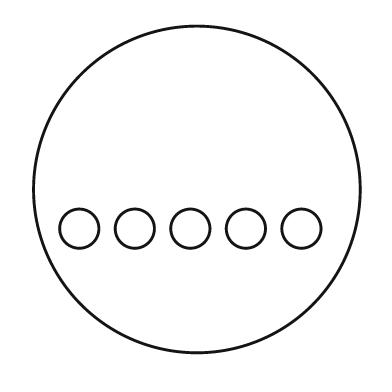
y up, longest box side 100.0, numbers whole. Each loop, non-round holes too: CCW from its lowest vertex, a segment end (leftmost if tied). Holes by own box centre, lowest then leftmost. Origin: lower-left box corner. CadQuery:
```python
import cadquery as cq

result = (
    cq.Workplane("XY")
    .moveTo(50.0, 50.0)
    .circle(50.0)
    .moveTo(14.0, 38.0)
    .circle(6.0)
    .moveTo(31.0, 38.0)
    .circle(6.0)
    .moveTo(48.0, 38.0)
    .circle(6.0)
    .moveTo(65.0, 38.0)
    .circle(6.0)
    .moveTo(82.0, 38.0)
    .circle(6.0)
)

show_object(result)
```